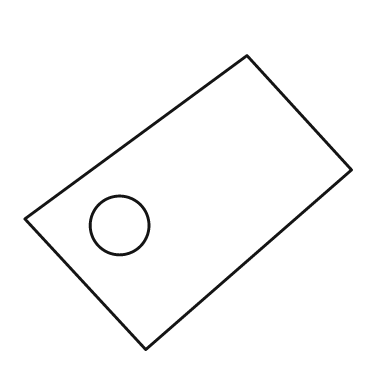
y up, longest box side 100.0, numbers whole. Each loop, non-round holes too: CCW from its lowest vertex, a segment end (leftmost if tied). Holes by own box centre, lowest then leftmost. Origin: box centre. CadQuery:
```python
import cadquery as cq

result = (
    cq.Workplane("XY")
    .moveTo(-13.0, -45.0)
    .lineTo(50.0, 10.0)
    .lineTo(18.0, 45.0)
    .lineTo(-50.0, -5.0)
    .close()
    .moveTo(-21.0, -7.0)
    .circle(9.0)
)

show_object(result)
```